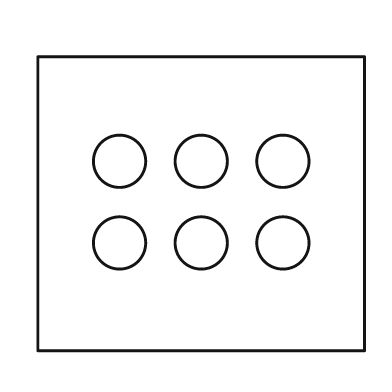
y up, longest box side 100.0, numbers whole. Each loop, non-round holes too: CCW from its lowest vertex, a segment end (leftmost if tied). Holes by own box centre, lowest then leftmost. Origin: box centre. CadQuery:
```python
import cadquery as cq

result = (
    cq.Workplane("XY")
    .moveTo(-50.0, -45.0)
    .lineTo(50.0, -45.0)
    .lineTo(50.0, 45.0)
    .lineTo(-50.0, 45.0)
    .close()
    .moveTo(-25.0, -12.0)
    .circle(8.0)
    .moveTo(0.0, -12.0)
    .circle(8.0)
    .moveTo(25.0, -12.0)
    .circle(8.0)
    .moveTo(-25.0, 13.0)
    .circle(8.0)
    .moveTo(0.0, 13.0)
    .circle(8.0)
    .moveTo(25.0, 13.0)
    .circle(8.0)
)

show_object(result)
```